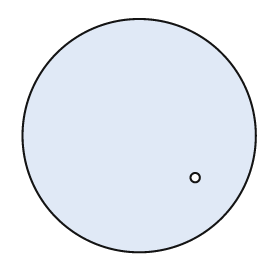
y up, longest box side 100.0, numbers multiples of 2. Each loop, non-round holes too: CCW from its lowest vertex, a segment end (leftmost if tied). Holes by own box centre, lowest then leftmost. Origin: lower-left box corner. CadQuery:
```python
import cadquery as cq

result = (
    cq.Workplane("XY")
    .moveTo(50.0, 50.0)
    .circle(50.0)
    .moveTo(74.0, 32.0)
    .circle(2.0)
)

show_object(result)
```